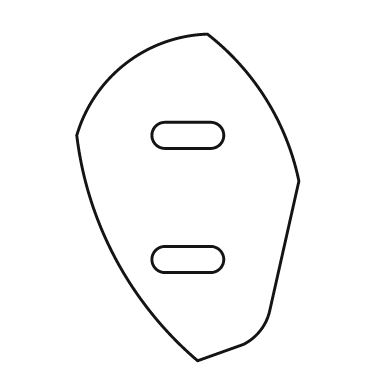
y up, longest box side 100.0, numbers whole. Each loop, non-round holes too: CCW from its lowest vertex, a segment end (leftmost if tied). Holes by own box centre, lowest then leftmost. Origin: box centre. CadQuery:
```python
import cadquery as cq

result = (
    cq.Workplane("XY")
    .moveTo(3.0, -50.0)
    .lineTo(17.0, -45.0)
    .threePointArc((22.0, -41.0), (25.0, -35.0))
    .lineTo(34.0, 5.0)
    .threePointArc((24.0, 30.0), (6.0, 50.0))
    .threePointArc((-19.0, 41.0), (-34.0, 19.0))
    .threePointArc((-22.0, -19.0), (3.0, -50.0))
    .close()
    .moveTo(-7.0, -23.0)
    .lineTo(7.0, -23.0)
    .threePointArc((11.0, -19.0), (7.0, -15.0))
    .lineTo(-7.0, -15.0)
    .threePointArc((-11.0, -19.0), (-7.0, -23.0))
    .close()
    .moveTo(-7.0, 15.0)
    .lineTo(7.0, 15.0)
    .threePointArc((11.0, 19.0), (7.0, 23.0))
    .lineTo(-7.0, 23.0)
    .threePointArc((-11.0, 19.0), (-7.0, 15.0))
    .close()
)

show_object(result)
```